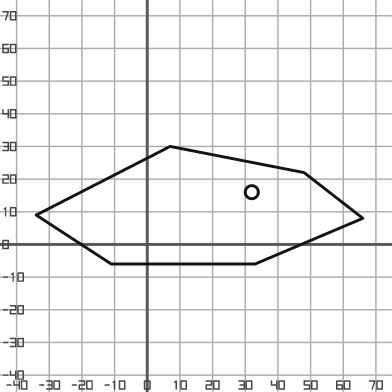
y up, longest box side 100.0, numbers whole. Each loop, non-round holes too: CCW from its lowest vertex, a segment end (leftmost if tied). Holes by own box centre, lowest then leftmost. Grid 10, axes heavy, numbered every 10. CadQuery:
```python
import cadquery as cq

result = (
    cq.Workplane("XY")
    .moveTo(-11.0, -6.0)
    .lineTo(33.0, -6.0)
    .lineTo(66.0, 8.0)
    .lineTo(48.0, 22.0)
    .lineTo(7.0, 30.0)
    .lineTo(-34.0, 9.0)
    .close()
    .moveTo(32.0, 16.0)
    .circle(2.0)
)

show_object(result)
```